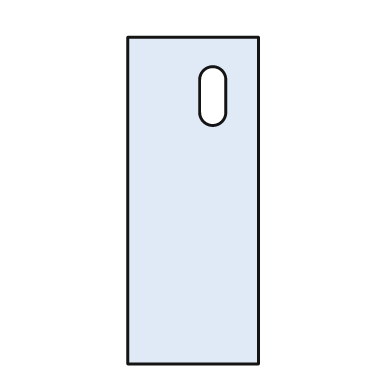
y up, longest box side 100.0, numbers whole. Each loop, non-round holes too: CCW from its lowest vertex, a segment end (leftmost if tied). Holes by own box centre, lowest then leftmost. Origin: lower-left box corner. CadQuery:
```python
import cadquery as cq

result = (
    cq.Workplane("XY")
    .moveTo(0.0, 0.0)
    .lineTo(40.0, 0.0)
    .lineTo(40.0, 100.0)
    .lineTo(0.0, 100.0)
    .close()
    .moveTo(22.0, 77.0)
    .threePointArc((26.0, 73.0), (30.0, 77.0))
    .lineTo(30.0, 87.0)
    .threePointArc((26.0, 91.0), (22.0, 87.0))
    .close()
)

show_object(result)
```